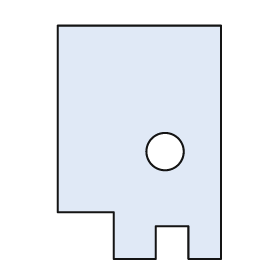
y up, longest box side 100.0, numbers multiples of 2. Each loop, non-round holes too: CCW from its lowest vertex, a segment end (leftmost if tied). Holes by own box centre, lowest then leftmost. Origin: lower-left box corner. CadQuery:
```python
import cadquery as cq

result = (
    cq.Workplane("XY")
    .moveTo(24.0, 0.0)
    .lineTo(42.0, 0.0)
    .lineTo(42.0, 14.0)
    .lineTo(56.0, 14.0)
    .lineTo(56.0, 0.0)
    .lineTo(70.0, 0.0)
    .lineTo(70.0, 100.0)
    .lineTo(0.0, 100.0)
    .lineTo(0.0, 20.0)
    .lineTo(24.0, 20.0)
    .close()
    .moveTo(46.0, 46.0)
    .circle(8.0)
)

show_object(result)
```